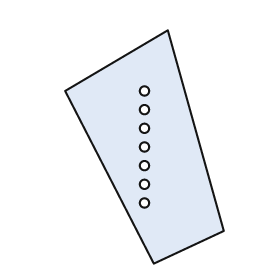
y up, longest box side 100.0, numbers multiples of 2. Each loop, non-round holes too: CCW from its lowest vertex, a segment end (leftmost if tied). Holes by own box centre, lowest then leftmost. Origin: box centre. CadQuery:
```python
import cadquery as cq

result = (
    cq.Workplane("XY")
    .moveTo(4.0, -50.0)
    .lineTo(34.0, -36.0)
    .lineTo(10.0, 50.0)
    .lineTo(-34.0, 24.0)
    .close()
    .moveTo(0.0, -24.0)
    .circle(2.0)
    .moveTo(0.0, -16.0)
    .circle(2.0)
    .moveTo(0.0, -8.0)
    .circle(2.0)
    .moveTo(0.0, 0.0)
    .circle(2.0)
    .moveTo(0.0, 8.0)
    .circle(2.0)
    .moveTo(0.0, 16.0)
    .circle(2.0)
    .moveTo(0.0, 24.0)
    .circle(2.0)
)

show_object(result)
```